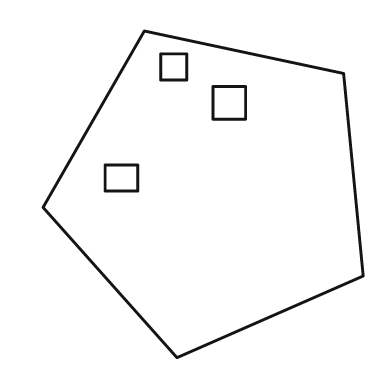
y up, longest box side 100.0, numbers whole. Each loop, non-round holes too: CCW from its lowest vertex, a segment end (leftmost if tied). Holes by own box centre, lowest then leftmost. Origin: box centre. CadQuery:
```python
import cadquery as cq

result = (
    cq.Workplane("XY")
    .moveTo(-8.0, -50.0)
    .lineTo(49.0, -25.0)
    .lineTo(43.0, 37.0)
    .lineTo(-18.0, 50.0)
    .lineTo(-49.0, -4.0)
    .close()
    .moveTo(-30.0, 1.0)
    .lineTo(-20.0, 1.0)
    .lineTo(-20.0, 9.0)
    .lineTo(-30.0, 9.0)
    .close()
    .moveTo(3.0, 23.0)
    .lineTo(13.0, 23.0)
    .lineTo(13.0, 33.0)
    .lineTo(3.0, 33.0)
    .close()
    .moveTo(-13.0, 35.0)
    .lineTo(-5.0, 35.0)
    .lineTo(-5.0, 43.0)
    .lineTo(-13.0, 43.0)
    .close()
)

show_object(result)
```